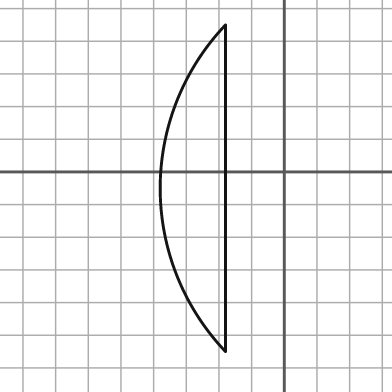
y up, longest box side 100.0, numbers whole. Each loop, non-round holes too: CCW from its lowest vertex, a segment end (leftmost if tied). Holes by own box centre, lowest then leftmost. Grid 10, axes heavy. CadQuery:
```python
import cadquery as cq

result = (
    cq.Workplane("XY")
    .moveTo(-18.0, -55.0)
    .lineTo(-18.0, 45.0)
    .threePointArc((-38.0, -5.0), (-18.0, -55.0))
    .close()
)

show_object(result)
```